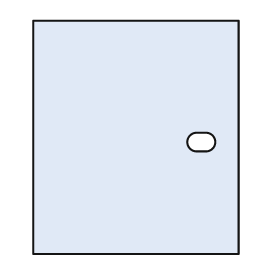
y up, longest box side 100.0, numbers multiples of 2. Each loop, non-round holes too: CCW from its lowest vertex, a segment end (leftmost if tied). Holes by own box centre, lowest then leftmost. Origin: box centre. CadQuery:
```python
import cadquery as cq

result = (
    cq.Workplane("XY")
    .moveTo(-44.0, -50.0)
    .lineTo(44.0, -50.0)
    .lineTo(44.0, 50.0)
    .lineTo(-44.0, 50.0)
    .close()
    .moveTo(26.0, -6.0)
    .lineTo(30.0, -6.0)
    .threePointArc((34.0, -2.0), (30.0, 2.0))
    .lineTo(26.0, 2.0)
    .threePointArc((22.0, -2.0), (26.0, -6.0))
    .close()
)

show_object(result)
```